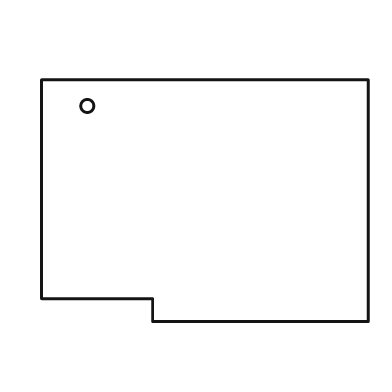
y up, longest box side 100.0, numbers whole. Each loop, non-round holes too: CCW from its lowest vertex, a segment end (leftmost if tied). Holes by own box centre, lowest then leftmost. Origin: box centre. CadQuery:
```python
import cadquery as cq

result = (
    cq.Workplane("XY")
    .moveTo(-16.0, -37.0)
    .lineTo(50.0, -37.0)
    .lineTo(50.0, 37.0)
    .lineTo(-50.0, 37.0)
    .lineTo(-50.0, -30.0)
    .lineTo(-16.0, -30.0)
    .close()
    .moveTo(-36.0, 29.0)
    .circle(2.0)
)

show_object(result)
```